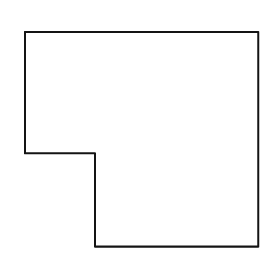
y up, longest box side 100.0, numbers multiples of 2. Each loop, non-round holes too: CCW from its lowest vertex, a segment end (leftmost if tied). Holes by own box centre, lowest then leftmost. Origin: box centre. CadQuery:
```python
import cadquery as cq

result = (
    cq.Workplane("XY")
    .moveTo(-20.0, -46.0)
    .lineTo(50.0, -46.0)
    .lineTo(50.0, 46.0)
    .lineTo(-50.0, 46.0)
    .lineTo(-50.0, -6.0)
    .lineTo(-20.0, -6.0)
    .close()
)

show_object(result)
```